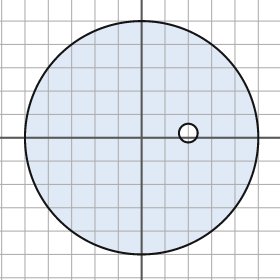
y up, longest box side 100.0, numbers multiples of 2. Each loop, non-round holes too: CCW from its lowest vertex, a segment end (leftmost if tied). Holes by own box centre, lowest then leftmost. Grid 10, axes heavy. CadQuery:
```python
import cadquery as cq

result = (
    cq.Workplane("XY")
    .moveTo(0.0, 0.0)
    .circle(50.0)
    .moveTo(20.0, 2.0)
    .circle(4.0)
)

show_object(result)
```